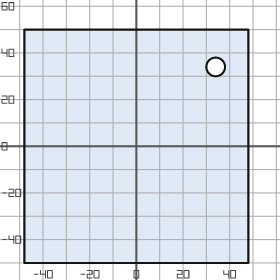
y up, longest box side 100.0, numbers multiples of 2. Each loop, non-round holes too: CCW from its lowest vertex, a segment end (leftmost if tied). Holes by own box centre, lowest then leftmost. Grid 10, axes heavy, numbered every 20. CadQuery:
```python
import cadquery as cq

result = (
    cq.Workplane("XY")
    .moveTo(-48.0, -50.0)
    .lineTo(48.0, -50.0)
    .lineTo(48.0, 50.0)
    .lineTo(-48.0, 50.0)
    .close()
    .moveTo(34.0, 34.0)
    .circle(4.0)
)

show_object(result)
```